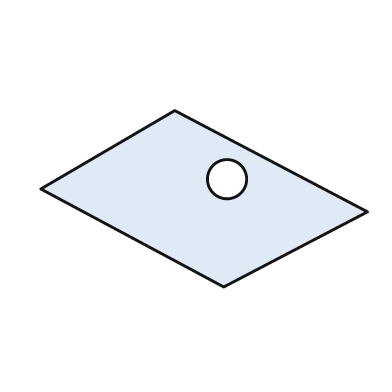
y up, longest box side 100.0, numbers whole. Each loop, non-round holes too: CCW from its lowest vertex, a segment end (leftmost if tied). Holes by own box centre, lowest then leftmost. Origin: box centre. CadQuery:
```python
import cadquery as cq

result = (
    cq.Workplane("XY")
    .moveTo(6.0, -27.0)
    .lineTo(50.0, -4.0)
    .lineTo(-9.0, 27.0)
    .lineTo(-50.0, 3.0)
    .close()
    .moveTo(7.0, 6.0)
    .circle(6.0)
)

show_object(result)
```